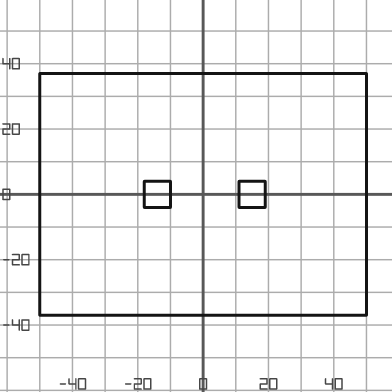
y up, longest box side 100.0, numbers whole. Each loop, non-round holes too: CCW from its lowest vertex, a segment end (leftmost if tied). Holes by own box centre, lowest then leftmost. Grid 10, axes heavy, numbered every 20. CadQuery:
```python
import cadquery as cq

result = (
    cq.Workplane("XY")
    .moveTo(-50.0, -37.0)
    .lineTo(50.0, -37.0)
    .lineTo(50.0, 37.0)
    .lineTo(-50.0, 37.0)
    .close()
    .moveTo(-18.0, -4.0)
    .lineTo(-10.0, -4.0)
    .lineTo(-10.0, 4.0)
    .lineTo(-18.0, 4.0)
    .close()
    .moveTo(11.0, -4.0)
    .lineTo(19.0, -4.0)
    .lineTo(19.0, 4.0)
    .lineTo(11.0, 4.0)
    .close()
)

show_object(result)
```